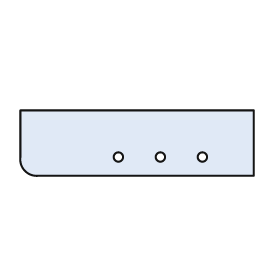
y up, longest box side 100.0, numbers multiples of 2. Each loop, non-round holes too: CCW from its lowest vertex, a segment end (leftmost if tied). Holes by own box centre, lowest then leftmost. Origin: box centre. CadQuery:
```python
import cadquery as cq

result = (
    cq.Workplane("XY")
    .moveTo(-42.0, -14.0)
    .lineTo(50.0, -14.0)
    .lineTo(50.0, 14.0)
    .lineTo(-50.0, 14.0)
    .lineTo(-50.0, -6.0)
    .threePointArc((-48.0, -12.0), (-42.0, -14.0))
    .close()
    .moveTo(-8.0, -6.0)
    .circle(2.0)
    .moveTo(10.0, -6.0)
    .circle(2.0)
    .moveTo(28.0, -6.0)
    .circle(2.0)
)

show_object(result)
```